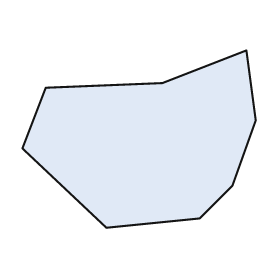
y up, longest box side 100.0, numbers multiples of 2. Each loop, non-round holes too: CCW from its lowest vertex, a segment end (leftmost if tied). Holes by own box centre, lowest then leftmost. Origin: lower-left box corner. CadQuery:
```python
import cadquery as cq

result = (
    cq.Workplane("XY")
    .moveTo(36.0, 0.0)
    .lineTo(76.0, 4.0)
    .lineTo(90.0, 18.0)
    .lineTo(100.0, 46.0)
    .lineTo(96.0, 76.0)
    .lineTo(60.0, 62.0)
    .lineTo(10.0, 60.0)
    .lineTo(0.0, 34.0)
    .close()
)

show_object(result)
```